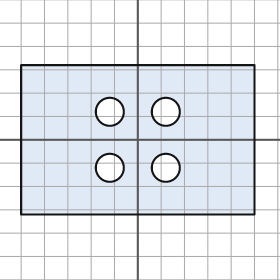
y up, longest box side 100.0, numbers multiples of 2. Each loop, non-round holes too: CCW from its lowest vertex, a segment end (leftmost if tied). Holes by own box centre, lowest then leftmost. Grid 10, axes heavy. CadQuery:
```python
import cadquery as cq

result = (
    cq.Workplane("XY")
    .moveTo(-50.0, -32.0)
    .lineTo(50.0, -32.0)
    .lineTo(50.0, 32.0)
    .lineTo(-50.0, 32.0)
    .close()
    .moveTo(-12.0, -12.0)
    .circle(6.0)
    .moveTo(12.0, -12.0)
    .circle(6.0)
    .moveTo(-12.0, 12.0)
    .circle(6.0)
    .moveTo(12.0, 12.0)
    .circle(6.0)
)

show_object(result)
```